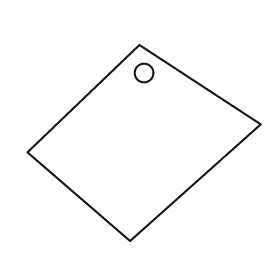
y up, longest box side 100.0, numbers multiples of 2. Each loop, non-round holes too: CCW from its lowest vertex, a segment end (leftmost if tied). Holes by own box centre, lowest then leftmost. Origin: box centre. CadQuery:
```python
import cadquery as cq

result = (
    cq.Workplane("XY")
    .moveTo(-6.0, -42.0)
    .lineTo(50.0, 8.0)
    .lineTo(-2.0, 42.0)
    .lineTo(-50.0, -4.0)
    .close()
    .moveTo(0.0, 30.0)
    .circle(4.0)
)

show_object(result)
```